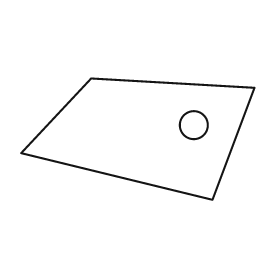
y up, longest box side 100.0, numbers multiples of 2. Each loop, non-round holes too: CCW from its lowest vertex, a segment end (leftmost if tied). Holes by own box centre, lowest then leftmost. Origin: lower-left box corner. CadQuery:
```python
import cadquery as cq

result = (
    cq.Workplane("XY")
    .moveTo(82.0, 0.0)
    .lineTo(100.0, 48.0)
    .lineTo(30.0, 52.0)
    .lineTo(0.0, 20.0)
    .close()
    .moveTo(74.0, 32.0)
    .circle(6.0)
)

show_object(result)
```